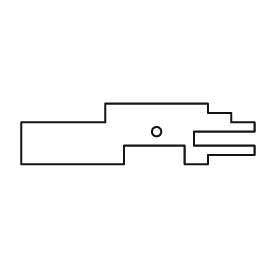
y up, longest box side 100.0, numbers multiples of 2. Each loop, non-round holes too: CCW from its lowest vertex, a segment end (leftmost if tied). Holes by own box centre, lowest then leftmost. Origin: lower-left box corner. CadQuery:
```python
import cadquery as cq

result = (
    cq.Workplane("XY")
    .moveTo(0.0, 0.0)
    .lineTo(44.0, 0.0)
    .lineTo(44.0, 8.0)
    .lineTo(70.0, 8.0)
    .lineTo(70.0, 0.0)
    .lineTo(80.0, 0.0)
    .lineTo(80.0, 4.0)
    .lineTo(100.0, 4.0)
    .lineTo(100.0, 8.0)
    .lineTo(74.0, 8.0)
    .lineTo(74.0, 14.0)
    .lineTo(100.0, 14.0)
    .lineTo(100.0, 18.0)
    .lineTo(90.0, 18.0)
    .lineTo(90.0, 22.0)
    .lineTo(80.0, 22.0)
    .lineTo(80.0, 26.0)
    .lineTo(36.0, 26.0)
    .lineTo(36.0, 18.0)
    .lineTo(0.0, 18.0)
    .close()
    .moveTo(58.0, 14.0)
    .circle(2.0)
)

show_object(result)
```